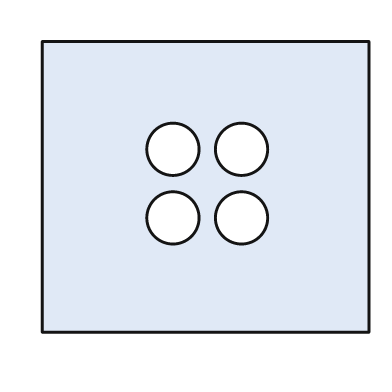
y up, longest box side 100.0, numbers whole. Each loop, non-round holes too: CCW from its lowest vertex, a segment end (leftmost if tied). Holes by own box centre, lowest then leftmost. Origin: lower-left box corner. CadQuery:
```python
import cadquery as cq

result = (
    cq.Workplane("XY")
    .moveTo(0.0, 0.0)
    .lineTo(100.0, 0.0)
    .lineTo(100.0, 89.0)
    .lineTo(0.0, 89.0)
    .close()
    .moveTo(40.0, 35.0)
    .circle(8.0)
    .moveTo(61.0, 35.0)
    .circle(8.0)
    .moveTo(40.0, 56.0)
    .circle(8.0)
    .moveTo(61.0, 56.0)
    .circle(8.0)
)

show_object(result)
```